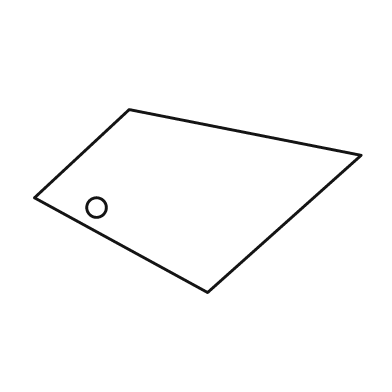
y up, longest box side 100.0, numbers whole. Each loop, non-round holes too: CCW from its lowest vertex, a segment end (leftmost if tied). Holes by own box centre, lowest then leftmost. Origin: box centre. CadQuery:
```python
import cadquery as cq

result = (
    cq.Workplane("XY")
    .moveTo(3.0, -28.0)
    .lineTo(50.0, 14.0)
    .lineTo(-21.0, 28.0)
    .lineTo(-50.0, 1.0)
    .close()
    .moveTo(-31.0, -2.0)
    .circle(3.0)
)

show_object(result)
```